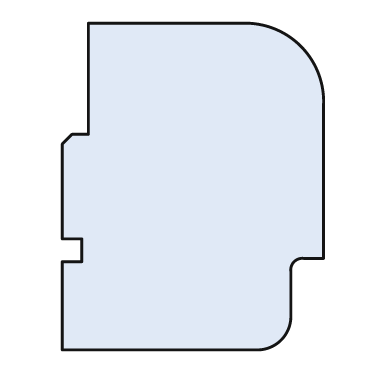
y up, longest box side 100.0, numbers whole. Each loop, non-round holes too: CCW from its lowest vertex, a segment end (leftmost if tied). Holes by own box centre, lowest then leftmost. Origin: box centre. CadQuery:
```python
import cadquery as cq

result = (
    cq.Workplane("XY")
    .moveTo(-40.0, -50.0)
    .lineTo(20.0, -50.0)
    .threePointArc((27.0, -47.0), (30.0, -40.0))
    .lineTo(30.0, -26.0)
    .threePointArc((31.0, -23.0), (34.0, -22.0))
    .lineTo(40.0, -22.0)
    .lineTo(40.0, 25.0)
    .threePointArc((33.0, 43.0), (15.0, 50.0))
    .lineTo(-32.0, 50.0)
    .lineTo(-32.0, 16.0)
    .lineTo(-37.0, 16.0)
    .lineTo(-40.0, 13.0)
    .lineTo(-40.0, -16.0)
    .lineTo(-34.0, -16.0)
    .lineTo(-34.0, -23.0)
    .lineTo(-40.0, -23.0)
    .close()
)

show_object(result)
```